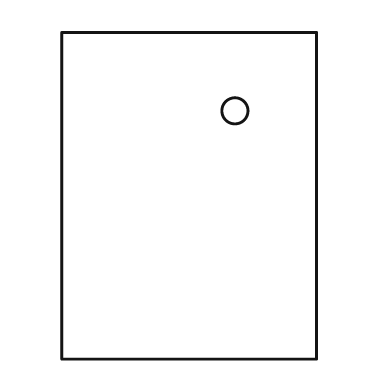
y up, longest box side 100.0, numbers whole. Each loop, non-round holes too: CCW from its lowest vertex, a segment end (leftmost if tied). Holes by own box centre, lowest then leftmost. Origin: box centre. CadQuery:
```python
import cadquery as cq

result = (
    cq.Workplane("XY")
    .moveTo(-39.0, -50.0)
    .lineTo(39.0, -50.0)
    .lineTo(39.0, 50.0)
    .lineTo(-39.0, 50.0)
    .close()
    .moveTo(14.0, 26.0)
    .circle(4.0)
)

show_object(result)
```